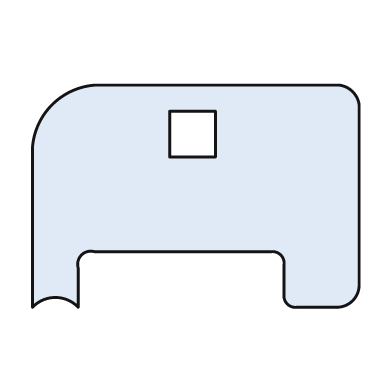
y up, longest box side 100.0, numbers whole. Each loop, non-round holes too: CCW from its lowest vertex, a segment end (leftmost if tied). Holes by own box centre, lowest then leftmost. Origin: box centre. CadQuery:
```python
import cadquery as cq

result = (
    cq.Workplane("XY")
    .moveTo(-50.0, -34.0)
    .threePointArc((-43.0, -31.0), (-36.0, -34.0))
    .lineTo(-36.0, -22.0)
    .threePointArc((-35.0, -18.0), (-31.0, -17.0))
    .lineTo(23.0, -17.0)
    .threePointArc((26.0, -18.0), (27.0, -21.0))
    .lineTo(27.0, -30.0)
    .threePointArc((28.0, -33.0), (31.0, -34.0))
    .lineTo(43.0, -34.0)
    .threePointArc((48.0, -32.0), (50.0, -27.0))
    .lineTo(50.0, 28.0)
    .threePointArc((48.0, 32.0), (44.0, 34.0))
    .lineTo(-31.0, 34.0)
    .threePointArc((-44.0, 28.0), (-50.0, 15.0))
    .close()
    .moveTo(-8.0, 12.0)
    .lineTo(6.0, 12.0)
    .lineTo(6.0, 26.0)
    .lineTo(-8.0, 26.0)
    .close()
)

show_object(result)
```